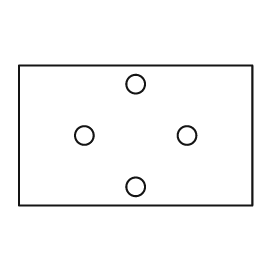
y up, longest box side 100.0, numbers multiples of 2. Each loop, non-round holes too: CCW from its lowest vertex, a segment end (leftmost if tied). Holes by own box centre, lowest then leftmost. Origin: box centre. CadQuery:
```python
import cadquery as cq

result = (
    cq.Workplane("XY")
    .moveTo(-50.0, -30.0)
    .lineTo(50.0, -30.0)
    .lineTo(50.0, 30.0)
    .lineTo(-50.0, 30.0)
    .close()
    .moveTo(0.0, -22.0)
    .circle(4.0)
    .moveTo(-22.0, 0.0)
    .circle(4.0)
    .moveTo(22.0, 0.0)
    .circle(4.0)
    .moveTo(0.0, 22.0)
    .circle(4.0)
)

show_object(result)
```